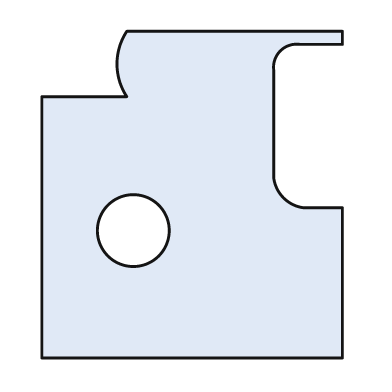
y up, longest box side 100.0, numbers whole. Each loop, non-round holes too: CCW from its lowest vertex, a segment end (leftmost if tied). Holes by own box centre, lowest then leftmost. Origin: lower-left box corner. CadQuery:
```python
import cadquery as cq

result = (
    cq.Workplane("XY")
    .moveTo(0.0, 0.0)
    .lineTo(92.0, 0.0)
    .lineTo(92.0, 46.0)
    .lineTo(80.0, 46.0)
    .threePointArc((74.0, 49.0), (71.0, 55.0))
    .lineTo(71.0, 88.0)
    .threePointArc((73.0, 94.0), (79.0, 96.0))
    .lineTo(92.0, 96.0)
    .lineTo(92.0, 100.0)
    .lineTo(26.0, 100.0)
    .threePointArc((23.0, 90.0), (26.0, 80.0))
    .lineTo(0.0, 80.0)
    .close()
    .moveTo(28.0, 39.0)
    .circle(11.0)
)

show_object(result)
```